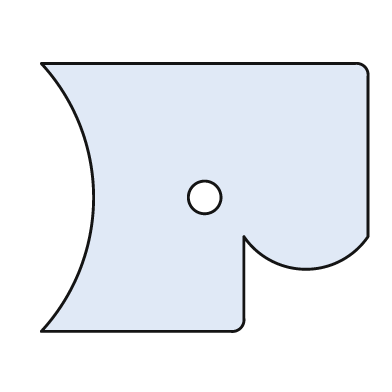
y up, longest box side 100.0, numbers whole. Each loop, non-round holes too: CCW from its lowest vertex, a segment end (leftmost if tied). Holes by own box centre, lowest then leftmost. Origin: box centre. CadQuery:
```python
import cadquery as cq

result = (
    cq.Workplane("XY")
    .moveTo(-50.0, -41.0)
    .lineTo(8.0, -41.0)
    .threePointArc((11.0, -40.0), (12.0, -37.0))
    .lineTo(12.0, -12.0)
    .threePointArc((31.0, -22.0), (50.0, -12.0))
    .lineTo(50.0, 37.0)
    .threePointArc((49.0, 40.0), (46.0, 41.0))
    .lineTo(-50.0, 41.0)
    .threePointArc((-34.0, 0.0), (-50.0, -41.0))
    .close()
    .moveTo(0.0, 0.0)
    .circle(5.0)
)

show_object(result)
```